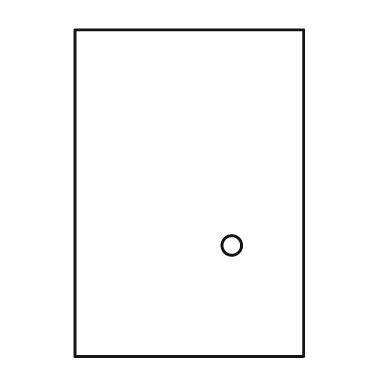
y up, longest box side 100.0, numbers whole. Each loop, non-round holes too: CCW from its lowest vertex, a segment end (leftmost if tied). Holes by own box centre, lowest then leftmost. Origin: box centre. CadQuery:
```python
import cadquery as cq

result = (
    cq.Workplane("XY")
    .moveTo(-35.0, -50.0)
    .lineTo(35.0, -50.0)
    .lineTo(35.0, 50.0)
    .lineTo(-35.0, 50.0)
    .close()
    .moveTo(13.0, -16.0)
    .circle(3.0)
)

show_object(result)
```